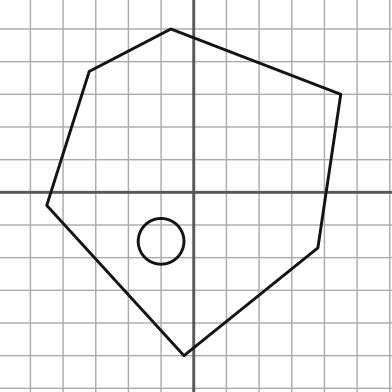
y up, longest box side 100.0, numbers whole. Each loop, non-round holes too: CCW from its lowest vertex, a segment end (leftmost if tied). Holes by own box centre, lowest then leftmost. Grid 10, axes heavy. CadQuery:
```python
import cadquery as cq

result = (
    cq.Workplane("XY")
    .moveTo(-3.0, -50.0)
    .lineTo(38.0, -17.0)
    .lineTo(45.0, 30.0)
    .lineTo(-7.0, 50.0)
    .lineTo(-32.0, 37.0)
    .lineTo(-45.0, -4.0)
    .close()
    .moveTo(-10.0, -15.0)
    .circle(7.0)
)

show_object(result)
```